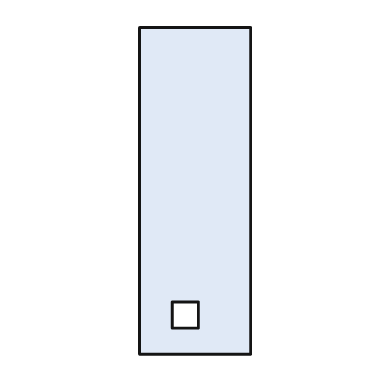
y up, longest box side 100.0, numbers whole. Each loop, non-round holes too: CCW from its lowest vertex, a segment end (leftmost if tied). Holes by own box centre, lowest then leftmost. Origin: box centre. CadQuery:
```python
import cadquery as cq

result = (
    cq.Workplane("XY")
    .moveTo(-17.0, -50.0)
    .lineTo(17.0, -50.0)
    .lineTo(17.0, 50.0)
    .lineTo(-17.0, 50.0)
    .close()
    .moveTo(-7.0, -42.0)
    .lineTo(1.0, -42.0)
    .lineTo(1.0, -34.0)
    .lineTo(-7.0, -34.0)
    .close()
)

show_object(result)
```